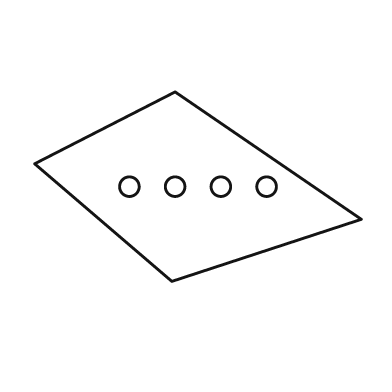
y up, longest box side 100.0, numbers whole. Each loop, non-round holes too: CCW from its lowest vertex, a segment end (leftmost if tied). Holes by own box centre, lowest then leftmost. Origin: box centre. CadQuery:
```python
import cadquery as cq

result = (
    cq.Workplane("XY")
    .moveTo(-8.0, -29.0)
    .lineTo(50.0, -10.0)
    .lineTo(-7.0, 29.0)
    .lineTo(-50.0, 7.0)
    .close()
    .moveTo(-21.0, 0.0)
    .circle(3.0)
    .moveTo(-7.0, 0.0)
    .circle(3.0)
    .moveTo(7.0, 0.0)
    .circle(3.0)
    .moveTo(21.0, 0.0)
    .circle(3.0)
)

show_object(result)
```